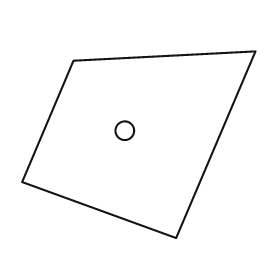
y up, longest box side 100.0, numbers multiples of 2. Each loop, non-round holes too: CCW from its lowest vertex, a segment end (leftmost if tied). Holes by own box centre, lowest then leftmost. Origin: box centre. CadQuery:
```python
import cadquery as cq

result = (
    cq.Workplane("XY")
    .moveTo(16.0, -40.0)
    .lineTo(50.0, 40.0)
    .lineTo(-28.0, 36.0)
    .lineTo(-50.0, -16.0)
    .close()
    .moveTo(-6.0, 6.0)
    .circle(4.0)
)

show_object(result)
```